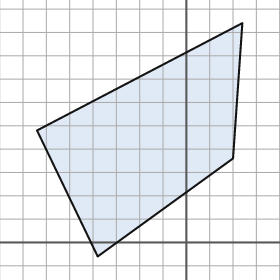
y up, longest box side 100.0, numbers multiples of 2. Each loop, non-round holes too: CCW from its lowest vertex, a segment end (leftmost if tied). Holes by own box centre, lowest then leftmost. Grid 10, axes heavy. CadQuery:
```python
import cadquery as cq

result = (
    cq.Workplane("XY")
    .moveTo(-38.0, -6.0)
    .lineTo(20.0, 36.0)
    .lineTo(24.0, 94.0)
    .lineTo(-64.0, 48.0)
    .close()
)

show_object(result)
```